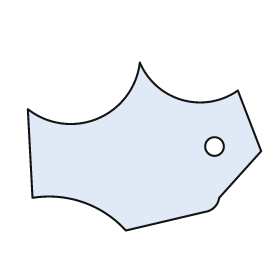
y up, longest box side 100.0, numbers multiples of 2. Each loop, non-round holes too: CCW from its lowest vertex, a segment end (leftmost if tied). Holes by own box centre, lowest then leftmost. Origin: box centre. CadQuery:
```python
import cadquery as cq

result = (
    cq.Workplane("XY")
    .moveTo(-8.0, -36.0)
    .lineTo(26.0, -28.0)
    .threePointArc((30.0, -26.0), (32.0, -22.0))
    .lineTo(50.0, -2.0)
    .lineTo(40.0, 24.0)
    .threePointArc((16.0, 20.0), (-2.0, 36.0))
    .threePointArc((-20.0, 12.0), (-50.0, 16.0))
    .lineTo(-48.0, -22.0)
    .threePointArc((-26.0, -24.0), (-8.0, -36.0))
    .close()
    .moveTo(30.0, 0.0)
    .circle(4.0)
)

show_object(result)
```